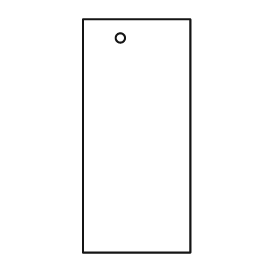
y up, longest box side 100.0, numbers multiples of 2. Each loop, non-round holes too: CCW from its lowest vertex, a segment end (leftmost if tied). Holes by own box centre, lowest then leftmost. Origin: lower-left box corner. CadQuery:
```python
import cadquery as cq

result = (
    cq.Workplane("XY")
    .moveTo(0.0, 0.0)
    .lineTo(46.0, 0.0)
    .lineTo(46.0, 100.0)
    .lineTo(0.0, 100.0)
    .close()
    .moveTo(16.0, 92.0)
    .circle(2.0)
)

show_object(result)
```